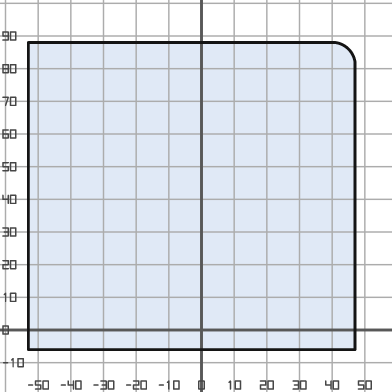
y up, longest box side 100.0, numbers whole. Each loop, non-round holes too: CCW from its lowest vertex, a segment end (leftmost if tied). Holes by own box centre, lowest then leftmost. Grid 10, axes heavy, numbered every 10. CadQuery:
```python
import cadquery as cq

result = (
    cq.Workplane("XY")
    .moveTo(-53.0, -6.0)
    .lineTo(47.0, -6.0)
    .lineTo(47.0, 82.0)
    .threePointArc((45.0, 86.0), (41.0, 88.0))
    .lineTo(-53.0, 88.0)
    .close()
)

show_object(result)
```